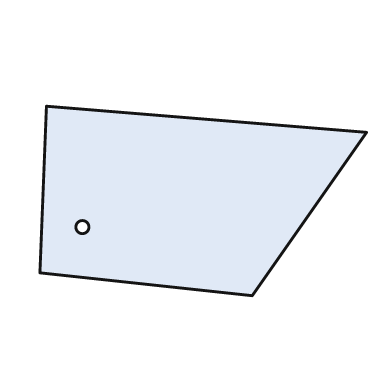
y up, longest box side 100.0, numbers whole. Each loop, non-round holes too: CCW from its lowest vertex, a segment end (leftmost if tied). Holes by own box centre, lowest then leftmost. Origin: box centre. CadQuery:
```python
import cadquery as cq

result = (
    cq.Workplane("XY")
    .moveTo(15.0, -29.0)
    .lineTo(50.0, 21.0)
    .lineTo(-48.0, 29.0)
    .lineTo(-50.0, -22.0)
    .close()
    .moveTo(-37.0, -8.0)
    .circle(2.0)
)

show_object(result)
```